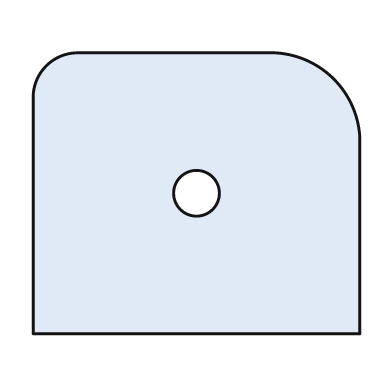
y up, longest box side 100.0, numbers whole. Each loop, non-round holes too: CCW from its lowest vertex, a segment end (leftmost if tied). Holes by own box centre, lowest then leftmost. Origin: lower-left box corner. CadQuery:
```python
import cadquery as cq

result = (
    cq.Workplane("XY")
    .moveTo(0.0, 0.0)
    .lineTo(100.0, 0.0)
    .lineTo(100.0, 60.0)
    .threePointArc((92.0, 78.0), (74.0, 86.0))
    .lineTo(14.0, 86.0)
    .threePointArc((4.0, 82.0), (0.0, 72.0))
    .close()
    .moveTo(50.0, 43.0)
    .circle(7.0)
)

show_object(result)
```